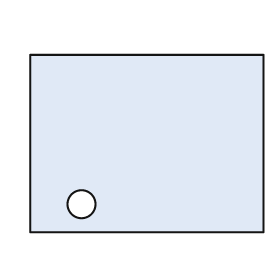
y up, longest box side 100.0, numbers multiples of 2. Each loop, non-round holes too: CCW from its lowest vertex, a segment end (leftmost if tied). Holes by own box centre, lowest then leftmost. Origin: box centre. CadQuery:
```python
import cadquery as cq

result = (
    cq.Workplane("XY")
    .moveTo(-50.0, -38.0)
    .lineTo(50.0, -38.0)
    .lineTo(50.0, 38.0)
    .lineTo(-50.0, 38.0)
    .close()
    .moveTo(-28.0, -26.0)
    .circle(6.0)
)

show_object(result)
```